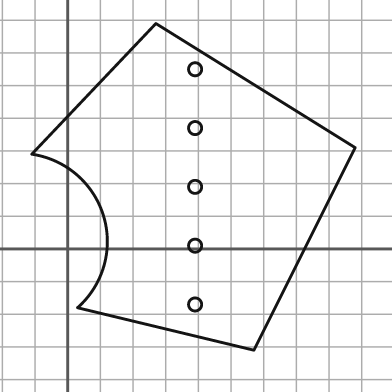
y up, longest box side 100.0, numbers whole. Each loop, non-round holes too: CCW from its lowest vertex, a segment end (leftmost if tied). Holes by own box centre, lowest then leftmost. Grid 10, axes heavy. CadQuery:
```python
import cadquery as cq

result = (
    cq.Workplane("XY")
    .moveTo(57.0, -31.0)
    .lineTo(88.0, 31.0)
    .lineTo(27.0, 69.0)
    .lineTo(-11.0, 29.0)
    .threePointArc((11.0, 10.0), (3.0, -18.0))
    .close()
    .moveTo(39.0, -17.0)
    .circle(2.0)
    .moveTo(39.0, 1.0)
    .circle(2.0)
    .moveTo(39.0, 19.0)
    .circle(2.0)
    .moveTo(39.0, 37.0)
    .circle(2.0)
    .moveTo(39.0, 55.0)
    .circle(2.0)
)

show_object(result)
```